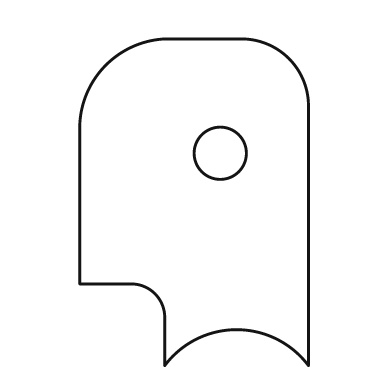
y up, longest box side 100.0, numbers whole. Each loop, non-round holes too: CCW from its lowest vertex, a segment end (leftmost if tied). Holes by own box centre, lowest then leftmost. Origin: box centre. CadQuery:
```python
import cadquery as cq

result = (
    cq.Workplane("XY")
    .moveTo(-9.0, -50.0)
    .threePointArc((13.0, -39.0), (35.0, -50.0))
    .lineTo(35.0, 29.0)
    .threePointArc((29.0, 44.0), (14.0, 50.0))
    .lineTo(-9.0, 50.0)
    .threePointArc((-27.0, 42.0), (-35.0, 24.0))
    .lineTo(-35.0, -25.0)
    .lineTo(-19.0, -25.0)
    .threePointArc((-12.0, -28.0), (-9.0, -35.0))
    .close()
    .moveTo(8.0, 15.0)
    .circle(8.0)
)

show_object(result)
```